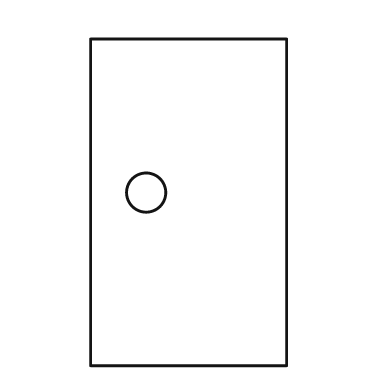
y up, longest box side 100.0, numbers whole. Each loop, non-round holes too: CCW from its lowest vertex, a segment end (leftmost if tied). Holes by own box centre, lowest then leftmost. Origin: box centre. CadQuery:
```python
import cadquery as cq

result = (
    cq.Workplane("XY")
    .moveTo(-30.0, -50.0)
    .lineTo(30.0, -50.0)
    .lineTo(30.0, 50.0)
    .lineTo(-30.0, 50.0)
    .close()
    .moveTo(-13.0, 3.0)
    .circle(6.0)
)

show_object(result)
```